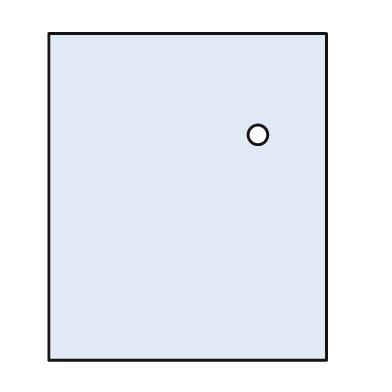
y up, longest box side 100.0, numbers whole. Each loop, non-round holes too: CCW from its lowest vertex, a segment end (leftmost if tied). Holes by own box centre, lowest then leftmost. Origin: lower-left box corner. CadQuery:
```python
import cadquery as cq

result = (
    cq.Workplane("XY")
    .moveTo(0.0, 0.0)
    .lineTo(85.0, 0.0)
    .lineTo(85.0, 100.0)
    .lineTo(0.0, 100.0)
    .close()
    .moveTo(64.0, 69.0)
    .circle(3.0)
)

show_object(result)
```